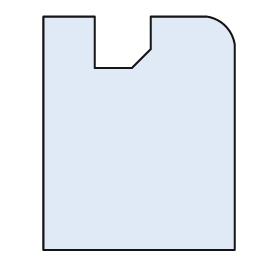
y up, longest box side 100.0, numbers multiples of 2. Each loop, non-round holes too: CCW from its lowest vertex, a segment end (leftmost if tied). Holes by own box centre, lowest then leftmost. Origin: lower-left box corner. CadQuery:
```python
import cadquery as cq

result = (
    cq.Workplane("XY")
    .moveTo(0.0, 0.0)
    .lineTo(82.0, 0.0)
    .lineTo(82.0, 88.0)
    .threePointArc((78.0, 96.0), (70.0, 100.0))
    .lineTo(46.0, 100.0)
    .lineTo(46.0, 86.0)
    .lineTo(38.0, 78.0)
    .lineTo(22.0, 78.0)
    .lineTo(22.0, 100.0)
    .lineTo(0.0, 100.0)
    .close()
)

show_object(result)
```